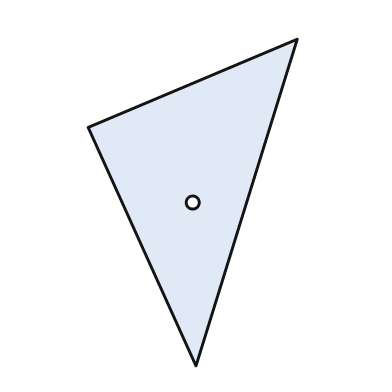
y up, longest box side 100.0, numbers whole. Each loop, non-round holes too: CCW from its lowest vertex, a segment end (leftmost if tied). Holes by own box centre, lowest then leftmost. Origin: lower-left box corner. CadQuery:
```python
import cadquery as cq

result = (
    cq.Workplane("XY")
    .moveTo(33.0, 0.0)
    .lineTo(64.0, 100.0)
    .lineTo(0.0, 73.0)
    .close()
    .moveTo(32.0, 50.0)
    .circle(2.0)
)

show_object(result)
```